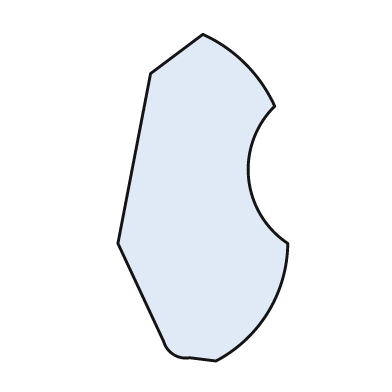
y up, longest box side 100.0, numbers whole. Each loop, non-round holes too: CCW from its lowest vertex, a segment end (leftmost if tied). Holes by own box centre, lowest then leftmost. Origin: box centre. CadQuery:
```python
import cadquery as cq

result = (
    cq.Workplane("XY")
    .moveTo(4.0, -50.0)
    .threePointArc((20.0, -35.0), (26.0, -14.0))
    .threePointArc((14.0, 6.0), (22.0, 28.0))
    .threePointArc((13.0, 41.0), (0.0, 50.0))
    .lineTo(-16.0, 38.0)
    .lineTo(-26.0, -14.0)
    .lineTo(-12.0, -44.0)
    .threePointArc((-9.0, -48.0), (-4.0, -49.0))
    .close()
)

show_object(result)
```